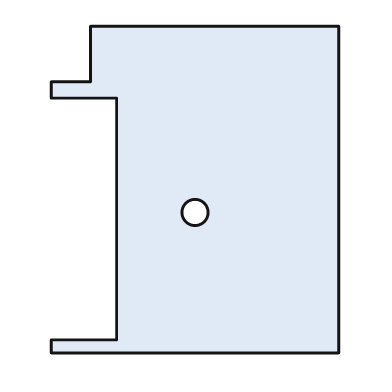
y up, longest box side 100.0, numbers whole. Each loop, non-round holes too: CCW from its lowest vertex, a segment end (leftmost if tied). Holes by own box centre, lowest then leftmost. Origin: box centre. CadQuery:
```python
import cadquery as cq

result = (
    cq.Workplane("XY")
    .moveTo(-44.0, -50.0)
    .lineTo(44.0, -50.0)
    .lineTo(44.0, 50.0)
    .lineTo(-32.0, 50.0)
    .lineTo(-32.0, 33.0)
    .lineTo(-44.0, 33.0)
    .lineTo(-44.0, 28.0)
    .lineTo(-24.0, 28.0)
    .lineTo(-24.0, -46.0)
    .lineTo(-44.0, -46.0)
    .close()
    .moveTo(0.0, -7.0)
    .circle(4.0)
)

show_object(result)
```